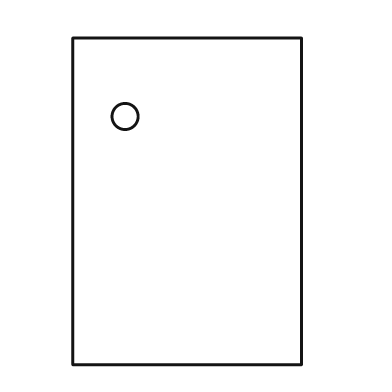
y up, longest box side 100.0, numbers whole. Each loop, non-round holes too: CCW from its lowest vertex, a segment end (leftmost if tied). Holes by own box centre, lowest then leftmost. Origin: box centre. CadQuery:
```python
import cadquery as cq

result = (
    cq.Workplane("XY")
    .moveTo(-35.0, -50.0)
    .lineTo(35.0, -50.0)
    .lineTo(35.0, 50.0)
    .lineTo(-35.0, 50.0)
    .close()
    .moveTo(-19.0, 26.0)
    .circle(4.0)
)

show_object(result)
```